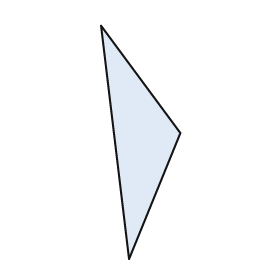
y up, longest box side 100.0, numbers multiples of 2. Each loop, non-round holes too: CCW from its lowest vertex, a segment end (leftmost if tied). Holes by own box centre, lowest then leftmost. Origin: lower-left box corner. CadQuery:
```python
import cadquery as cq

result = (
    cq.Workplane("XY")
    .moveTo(12.0, 0.0)
    .lineTo(34.0, 54.0)
    .lineTo(0.0, 100.0)
    .close()
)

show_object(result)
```